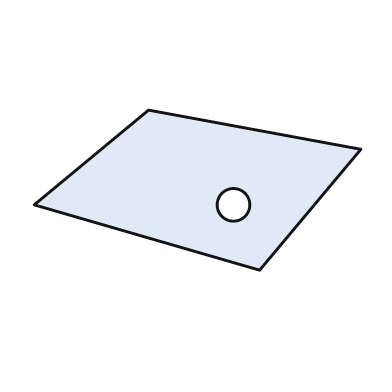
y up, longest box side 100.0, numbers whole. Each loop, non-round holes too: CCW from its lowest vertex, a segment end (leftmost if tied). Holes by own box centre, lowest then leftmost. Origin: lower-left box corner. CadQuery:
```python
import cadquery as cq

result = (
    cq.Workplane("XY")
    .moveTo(69.0, 0.0)
    .lineTo(100.0, 37.0)
    .lineTo(35.0, 49.0)
    .lineTo(0.0, 20.0)
    .close()
    .moveTo(61.0, 20.0)
    .circle(5.0)
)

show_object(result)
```